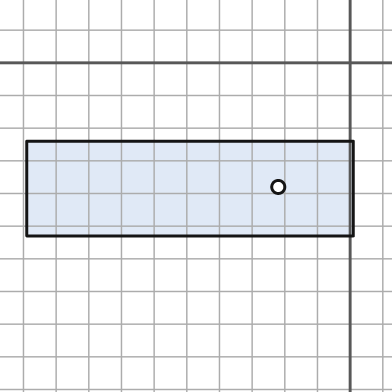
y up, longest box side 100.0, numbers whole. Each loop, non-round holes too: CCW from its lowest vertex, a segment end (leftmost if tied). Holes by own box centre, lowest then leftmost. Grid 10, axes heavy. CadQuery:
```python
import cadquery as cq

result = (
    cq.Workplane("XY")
    .moveTo(-99.0, -53.0)
    .lineTo(1.0, -53.0)
    .lineTo(1.0, -24.0)
    .lineTo(-99.0, -24.0)
    .close()
    .moveTo(-22.0, -38.0)
    .circle(2.0)
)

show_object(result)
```